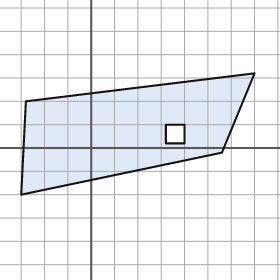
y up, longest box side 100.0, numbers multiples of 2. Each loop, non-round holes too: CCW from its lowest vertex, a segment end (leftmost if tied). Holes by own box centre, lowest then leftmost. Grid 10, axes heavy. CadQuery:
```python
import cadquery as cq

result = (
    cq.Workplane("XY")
    .moveTo(-30.0, -20.0)
    .lineTo(56.0, -2.0)
    .lineTo(70.0, 32.0)
    .lineTo(-28.0, 20.0)
    .close()
    .moveTo(32.0, 2.0)
    .lineTo(40.0, 2.0)
    .lineTo(40.0, 10.0)
    .lineTo(32.0, 10.0)
    .close()
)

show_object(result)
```